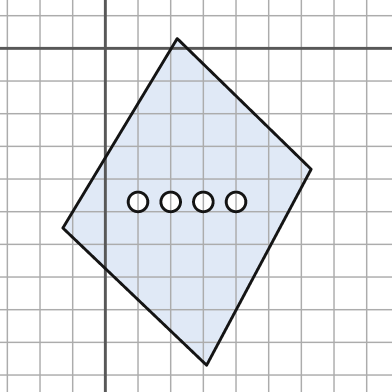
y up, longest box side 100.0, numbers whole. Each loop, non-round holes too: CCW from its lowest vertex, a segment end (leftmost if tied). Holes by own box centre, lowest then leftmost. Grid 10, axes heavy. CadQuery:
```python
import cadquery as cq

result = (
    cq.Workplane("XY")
    .moveTo(31.0, -97.0)
    .lineTo(63.0, -37.0)
    .lineTo(22.0, 3.0)
    .lineTo(-13.0, -55.0)
    .close()
    .moveTo(10.0, -47.0)
    .circle(3.0)
    .moveTo(20.0, -47.0)
    .circle(3.0)
    .moveTo(30.0, -47.0)
    .circle(3.0)
    .moveTo(40.0, -47.0)
    .circle(3.0)
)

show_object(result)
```